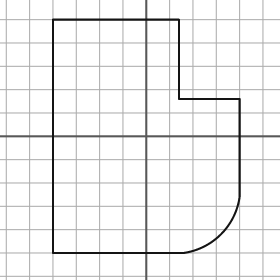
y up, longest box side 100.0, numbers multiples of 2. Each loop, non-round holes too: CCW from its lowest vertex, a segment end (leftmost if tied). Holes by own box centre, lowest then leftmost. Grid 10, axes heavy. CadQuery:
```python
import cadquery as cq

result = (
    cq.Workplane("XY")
    .moveTo(-40.0, -50.0)
    .lineTo(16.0, -50.0)
    .threePointArc((32.0, -42.0), (40.0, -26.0))
    .lineTo(40.0, 16.0)
    .lineTo(14.0, 16.0)
    .lineTo(14.0, 50.0)
    .lineTo(-40.0, 50.0)
    .close()
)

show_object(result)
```